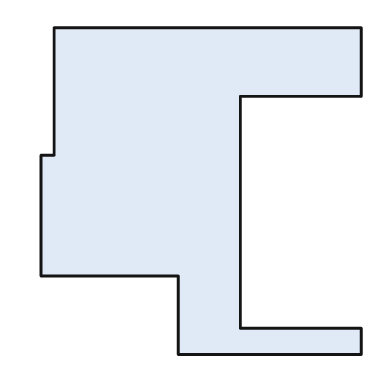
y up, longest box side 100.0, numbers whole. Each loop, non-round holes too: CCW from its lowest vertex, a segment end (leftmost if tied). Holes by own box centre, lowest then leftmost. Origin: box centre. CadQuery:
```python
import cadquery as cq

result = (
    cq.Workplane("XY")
    .moveTo(-7.0, -50.0)
    .lineTo(49.0, -50.0)
    .lineTo(49.0, -42.0)
    .lineTo(12.0, -42.0)
    .lineTo(12.0, 29.0)
    .lineTo(49.0, 29.0)
    .lineTo(49.0, 50.0)
    .lineTo(-45.0, 50.0)
    .lineTo(-45.0, 11.0)
    .lineTo(-49.0, 11.0)
    .lineTo(-49.0, -26.0)
    .lineTo(-7.0, -26.0)
    .close()
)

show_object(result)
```